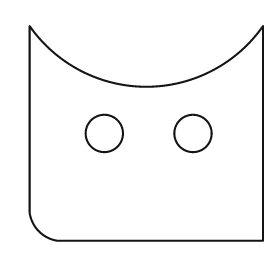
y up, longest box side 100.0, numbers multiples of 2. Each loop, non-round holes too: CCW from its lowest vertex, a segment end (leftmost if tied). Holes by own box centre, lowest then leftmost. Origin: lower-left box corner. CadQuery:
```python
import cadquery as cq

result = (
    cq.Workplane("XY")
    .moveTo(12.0, 0.0)
    .lineTo(100.0, 0.0)
    .lineTo(100.0, 92.0)
    .threePointArc((50.0, 66.0), (0.0, 92.0))
    .lineTo(0.0, 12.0)
    .threePointArc((4.0, 4.0), (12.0, 0.0))
    .close()
    .moveTo(32.0, 46.0)
    .circle(8.0)
    .moveTo(70.0, 46.0)
    .circle(8.0)
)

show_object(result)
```